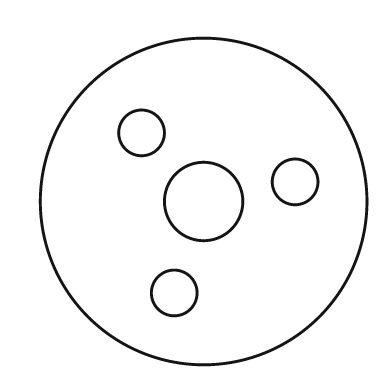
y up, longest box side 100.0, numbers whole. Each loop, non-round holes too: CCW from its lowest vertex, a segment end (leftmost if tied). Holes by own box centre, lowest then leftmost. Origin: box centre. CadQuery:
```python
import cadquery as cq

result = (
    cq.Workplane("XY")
    .moveTo(0.0, 0.0)
    .circle(50.0)
    .moveTo(-9.0, -28.0)
    .circle(7.0)
    .moveTo(0.0, 0.0)
    .circle(12.0)
    .moveTo(28.0, 6.0)
    .circle(7.0)
    .moveTo(-19.0, 21.0)
    .circle(7.0)
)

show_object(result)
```